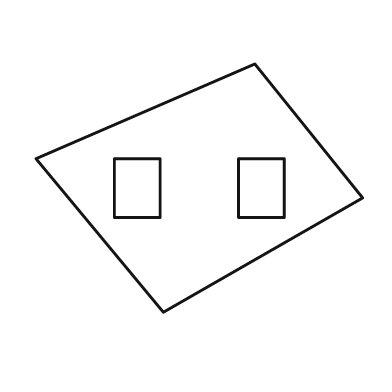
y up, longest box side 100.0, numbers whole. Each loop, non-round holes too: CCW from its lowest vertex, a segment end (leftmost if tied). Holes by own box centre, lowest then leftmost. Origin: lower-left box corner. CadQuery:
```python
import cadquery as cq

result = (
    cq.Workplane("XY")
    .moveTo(39.0, 0.0)
    .lineTo(100.0, 35.0)
    .lineTo(67.0, 76.0)
    .lineTo(0.0, 47.0)
    .close()
    .moveTo(24.0, 29.0)
    .lineTo(38.0, 29.0)
    .lineTo(38.0, 47.0)
    .lineTo(24.0, 47.0)
    .close()
    .moveTo(62.0, 29.0)
    .lineTo(76.0, 29.0)
    .lineTo(76.0, 47.0)
    .lineTo(62.0, 47.0)
    .close()
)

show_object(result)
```